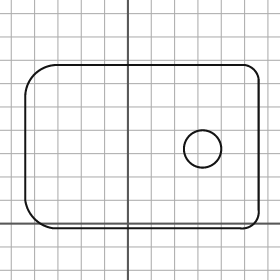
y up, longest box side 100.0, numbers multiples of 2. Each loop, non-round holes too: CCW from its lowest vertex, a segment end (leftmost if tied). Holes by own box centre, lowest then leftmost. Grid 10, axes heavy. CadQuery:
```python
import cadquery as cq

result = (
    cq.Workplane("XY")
    .moveTo(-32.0, -2.0)
    .lineTo(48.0, -2.0)
    .threePointArc((54.0, 0.0), (56.0, 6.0))
    .lineTo(56.0, 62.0)
    .threePointArc((54.0, 66.0), (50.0, 68.0))
    .lineTo(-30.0, 68.0)
    .threePointArc((-40.0, 64.0), (-44.0, 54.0))
    .lineTo(-44.0, 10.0)
    .threePointArc((-40.0, 2.0), (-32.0, -2.0))
    .close()
    .moveTo(32.0, 32.0)
    .circle(8.0)
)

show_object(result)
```